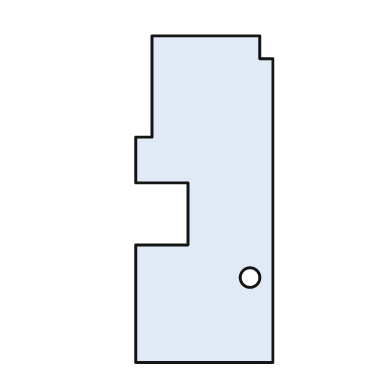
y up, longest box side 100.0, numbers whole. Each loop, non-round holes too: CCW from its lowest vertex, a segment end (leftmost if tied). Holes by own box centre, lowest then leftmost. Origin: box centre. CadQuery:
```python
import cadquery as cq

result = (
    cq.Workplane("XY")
    .moveTo(-21.0, -50.0)
    .lineTo(21.0, -50.0)
    .lineTo(21.0, 43.0)
    .lineTo(17.0, 43.0)
    .lineTo(17.0, 50.0)
    .lineTo(-16.0, 50.0)
    .lineTo(-16.0, 19.0)
    .lineTo(-21.0, 19.0)
    .lineTo(-21.0, 5.0)
    .lineTo(-5.0, 5.0)
    .lineTo(-5.0, -14.0)
    .lineTo(-21.0, -14.0)
    .close()
    .moveTo(14.0, -24.0)
    .circle(3.0)
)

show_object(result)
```